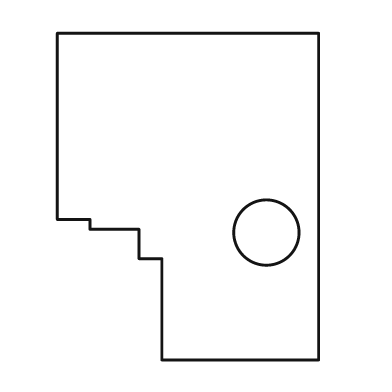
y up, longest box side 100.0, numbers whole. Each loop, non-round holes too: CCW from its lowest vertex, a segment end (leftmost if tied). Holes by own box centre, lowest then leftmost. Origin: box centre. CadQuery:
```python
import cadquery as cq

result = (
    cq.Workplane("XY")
    .moveTo(-8.0, -50.0)
    .lineTo(40.0, -50.0)
    .lineTo(40.0, 50.0)
    .lineTo(-40.0, 50.0)
    .lineTo(-40.0, -7.0)
    .lineTo(-30.0, -7.0)
    .lineTo(-30.0, -10.0)
    .lineTo(-15.0, -10.0)
    .lineTo(-15.0, -19.0)
    .lineTo(-8.0, -19.0)
    .close()
    .moveTo(24.0, -11.0)
    .circle(10.0)
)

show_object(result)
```